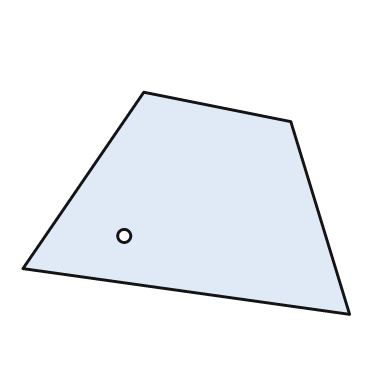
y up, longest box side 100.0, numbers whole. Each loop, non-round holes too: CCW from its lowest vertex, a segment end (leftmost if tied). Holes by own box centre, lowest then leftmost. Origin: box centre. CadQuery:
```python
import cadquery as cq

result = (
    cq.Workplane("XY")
    .moveTo(50.0, -34.0)
    .lineTo(32.0, 25.0)
    .lineTo(-13.0, 34.0)
    .lineTo(-50.0, -20.0)
    .close()
    .moveTo(-19.0, -10.0)
    .circle(2.0)
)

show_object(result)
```